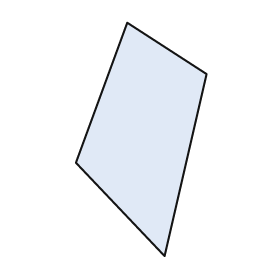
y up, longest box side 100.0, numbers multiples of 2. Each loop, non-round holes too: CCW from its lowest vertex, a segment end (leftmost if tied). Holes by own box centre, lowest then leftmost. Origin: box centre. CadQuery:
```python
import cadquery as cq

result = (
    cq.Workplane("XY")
    .moveTo(10.0, -50.0)
    .lineTo(28.0, 28.0)
    .lineTo(-6.0, 50.0)
    .lineTo(-28.0, -10.0)
    .close()
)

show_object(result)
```